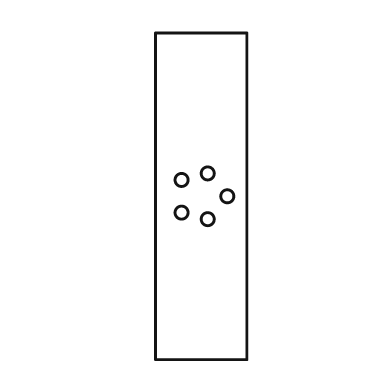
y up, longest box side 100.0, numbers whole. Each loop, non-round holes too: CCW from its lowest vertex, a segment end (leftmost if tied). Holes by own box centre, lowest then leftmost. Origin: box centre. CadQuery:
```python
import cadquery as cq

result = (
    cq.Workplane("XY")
    .moveTo(-14.0, -50.0)
    .lineTo(14.0, -50.0)
    .lineTo(14.0, 50.0)
    .lineTo(-14.0, 50.0)
    .close()
    .moveTo(2.0, -7.0)
    .circle(2.0)
    .moveTo(-6.0, -5.0)
    .circle(2.0)
    .moveTo(8.0, 0.0)
    .circle(2.0)
    .moveTo(-6.0, 5.0)
    .circle(2.0)
    .moveTo(2.0, 7.0)
    .circle(2.0)
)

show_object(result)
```